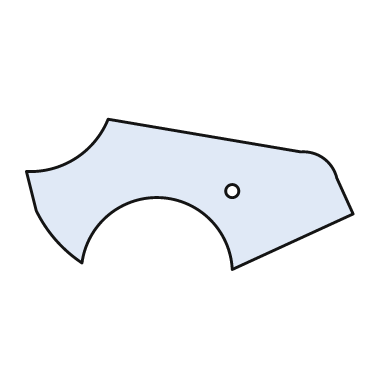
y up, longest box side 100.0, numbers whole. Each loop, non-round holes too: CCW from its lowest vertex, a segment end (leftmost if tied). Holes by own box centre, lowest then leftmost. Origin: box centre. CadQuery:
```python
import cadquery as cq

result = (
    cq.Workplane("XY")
    .moveTo(13.0, -23.0)
    .lineTo(50.0, -6.0)
    .lineTo(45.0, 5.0)
    .threePointArc((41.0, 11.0), (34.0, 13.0))
    .lineTo(-25.0, 23.0)
    .threePointArc((-35.0, 11.0), (-50.0, 7.0))
    .lineTo(-47.0, -5.0)
    .threePointArc((-41.0, -14.0), (-33.0, -21.0))
    .threePointArc((-9.0, -1.0), (13.0, -23.0))
    .close()
    .moveTo(13.0, 1.0)
    .circle(2.0)
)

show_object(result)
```